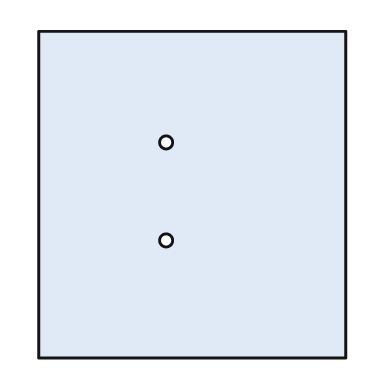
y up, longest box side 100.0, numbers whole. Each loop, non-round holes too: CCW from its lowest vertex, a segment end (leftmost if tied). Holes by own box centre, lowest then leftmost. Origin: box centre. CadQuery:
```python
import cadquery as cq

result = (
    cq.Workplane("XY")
    .moveTo(-47.0, -50.0)
    .lineTo(47.0, -50.0)
    .lineTo(47.0, 50.0)
    .lineTo(-47.0, 50.0)
    .close()
    .moveTo(-8.0, -14.0)
    .circle(2.0)
    .moveTo(-8.0, 16.0)
    .circle(2.0)
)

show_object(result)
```